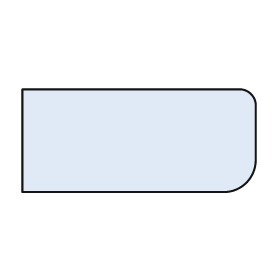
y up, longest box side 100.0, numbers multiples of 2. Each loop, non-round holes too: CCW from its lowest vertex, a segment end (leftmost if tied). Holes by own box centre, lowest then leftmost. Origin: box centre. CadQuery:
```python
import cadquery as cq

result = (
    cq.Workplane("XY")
    .moveTo(-50.0, -22.0)
    .lineTo(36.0, -22.0)
    .threePointArc((46.0, -18.0), (50.0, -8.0))
    .lineTo(50.0, 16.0)
    .threePointArc((48.0, 20.0), (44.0, 22.0))
    .lineTo(-50.0, 22.0)
    .close()
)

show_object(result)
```